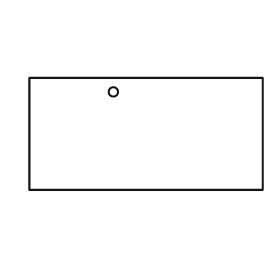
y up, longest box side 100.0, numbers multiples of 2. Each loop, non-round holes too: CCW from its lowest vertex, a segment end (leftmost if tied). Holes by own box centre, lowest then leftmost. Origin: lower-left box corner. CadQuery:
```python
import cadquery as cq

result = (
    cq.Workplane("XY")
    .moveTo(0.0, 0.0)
    .lineTo(100.0, 0.0)
    .lineTo(100.0, 48.0)
    .lineTo(0.0, 48.0)
    .close()
    .moveTo(36.0, 42.0)
    .circle(2.0)
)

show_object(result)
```